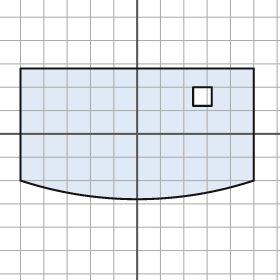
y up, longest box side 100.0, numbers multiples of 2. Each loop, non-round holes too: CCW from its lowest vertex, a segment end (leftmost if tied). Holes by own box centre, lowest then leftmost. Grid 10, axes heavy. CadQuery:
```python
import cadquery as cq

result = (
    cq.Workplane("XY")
    .moveTo(-50.0, -20.0)
    .threePointArc((0.0, -28.0), (50.0, -20.0))
    .lineTo(50.0, 28.0)
    .lineTo(-50.0, 28.0)
    .close()
    .moveTo(24.0, 12.0)
    .lineTo(32.0, 12.0)
    .lineTo(32.0, 20.0)
    .lineTo(24.0, 20.0)
    .close()
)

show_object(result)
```